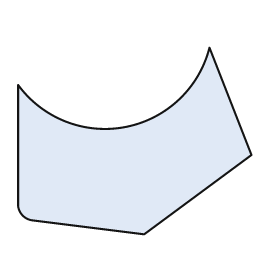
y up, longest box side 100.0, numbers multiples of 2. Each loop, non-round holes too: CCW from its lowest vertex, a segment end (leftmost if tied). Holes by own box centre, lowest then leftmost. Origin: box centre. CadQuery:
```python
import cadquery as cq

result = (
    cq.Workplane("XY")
    .moveTo(4.0, -40.0)
    .lineTo(50.0, -6.0)
    .lineTo(32.0, 40.0)
    .threePointArc((-4.0, 6.0), (-50.0, 24.0))
    .lineTo(-50.0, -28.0)
    .threePointArc((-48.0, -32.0), (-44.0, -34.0))
    .close()
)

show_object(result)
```